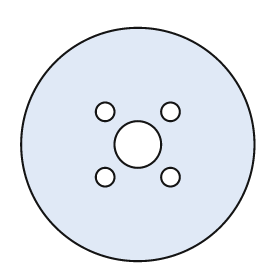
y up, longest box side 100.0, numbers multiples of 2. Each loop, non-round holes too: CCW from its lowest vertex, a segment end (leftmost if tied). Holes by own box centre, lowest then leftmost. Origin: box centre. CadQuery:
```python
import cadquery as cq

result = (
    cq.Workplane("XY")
    .moveTo(0.0, 0.0)
    .circle(50.0)
    .moveTo(-14.0, -14.0)
    .circle(4.0)
    .moveTo(14.0, -14.0)
    .circle(4.0)
    .moveTo(0.0, 0.0)
    .circle(10.0)
    .moveTo(-14.0, 14.0)
    .circle(4.0)
    .moveTo(14.0, 14.0)
    .circle(4.0)
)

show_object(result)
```